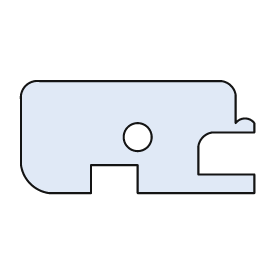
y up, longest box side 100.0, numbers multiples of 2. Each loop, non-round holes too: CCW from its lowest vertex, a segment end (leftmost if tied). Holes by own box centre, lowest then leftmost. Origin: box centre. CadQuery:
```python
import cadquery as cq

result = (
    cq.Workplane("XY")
    .moveTo(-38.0, -24.0)
    .lineTo(-20.0, -24.0)
    .lineTo(-20.0, -12.0)
    .lineTo(0.0, -12.0)
    .lineTo(0.0, -24.0)
    .lineTo(50.0, -24.0)
    .lineTo(50.0, -16.0)
    .lineTo(26.0, -16.0)
    .lineTo(26.0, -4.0)
    .threePointArc((28.0, 0.0), (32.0, 2.0))
    .lineTo(50.0, 2.0)
    .lineTo(50.0, 6.0)
    .threePointArc((46.0, 8.0), (42.0, 6.0))
    .lineTo(42.0, 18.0)
    .threePointArc((40.0, 22.0), (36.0, 24.0))
    .lineTo(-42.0, 24.0)
    .threePointArc((-48.0, 22.0), (-50.0, 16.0))
    .lineTo(-50.0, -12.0)
    .threePointArc((-46.0, -20.0), (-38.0, -24.0))
    .close()
    .moveTo(0.0, 0.0)
    .circle(6.0)
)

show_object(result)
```